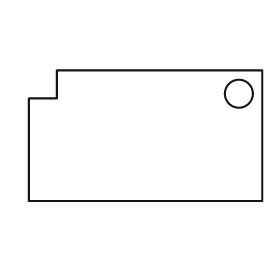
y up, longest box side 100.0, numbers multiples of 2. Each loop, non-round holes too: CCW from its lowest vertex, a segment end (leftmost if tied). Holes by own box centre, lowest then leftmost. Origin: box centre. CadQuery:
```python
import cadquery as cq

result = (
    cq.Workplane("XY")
    .moveTo(-50.0, -28.0)
    .lineTo(50.0, -28.0)
    .lineTo(50.0, 28.0)
    .lineTo(-38.0, 28.0)
    .lineTo(-38.0, 16.0)
    .lineTo(-50.0, 16.0)
    .close()
    .moveTo(40.0, 18.0)
    .circle(6.0)
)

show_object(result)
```